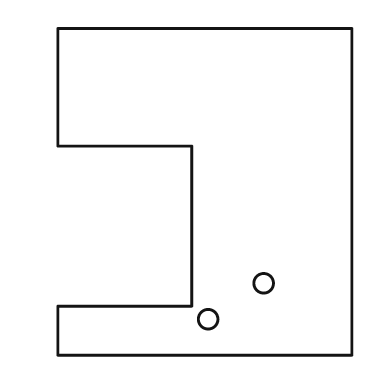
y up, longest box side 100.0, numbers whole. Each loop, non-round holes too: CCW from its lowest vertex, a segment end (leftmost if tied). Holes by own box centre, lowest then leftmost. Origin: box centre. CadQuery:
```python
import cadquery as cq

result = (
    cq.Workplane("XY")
    .moveTo(-45.0, -50.0)
    .lineTo(45.0, -50.0)
    .lineTo(45.0, 50.0)
    .lineTo(-45.0, 50.0)
    .lineTo(-45.0, 14.0)
    .lineTo(-4.0, 14.0)
    .lineTo(-4.0, -35.0)
    .lineTo(-45.0, -35.0)
    .close()
    .moveTo(1.0, -39.0)
    .circle(3.0)
    .moveTo(18.0, -28.0)
    .circle(3.0)
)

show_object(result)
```